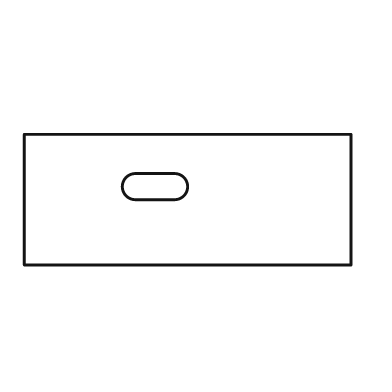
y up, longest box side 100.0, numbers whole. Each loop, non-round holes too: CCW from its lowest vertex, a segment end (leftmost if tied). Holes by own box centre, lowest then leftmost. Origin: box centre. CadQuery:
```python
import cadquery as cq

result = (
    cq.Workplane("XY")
    .moveTo(-50.0, -20.0)
    .lineTo(50.0, -20.0)
    .lineTo(50.0, 20.0)
    .lineTo(-50.0, 20.0)
    .close()
    .moveTo(-16.0, 0.0)
    .lineTo(-4.0, 0.0)
    .threePointArc((0.0, 4.0), (-4.0, 8.0))
    .lineTo(-16.0, 8.0)
    .threePointArc((-20.0, 4.0), (-16.0, 0.0))
    .close()
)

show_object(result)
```